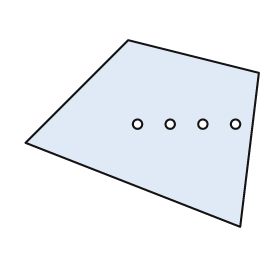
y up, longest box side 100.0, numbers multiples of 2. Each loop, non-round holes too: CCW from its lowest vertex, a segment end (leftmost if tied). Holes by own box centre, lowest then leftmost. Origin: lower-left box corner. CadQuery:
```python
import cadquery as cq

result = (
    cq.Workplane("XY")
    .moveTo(92.0, 0.0)
    .lineTo(100.0, 66.0)
    .lineTo(44.0, 80.0)
    .lineTo(0.0, 36.0)
    .close()
    .moveTo(48.0, 44.0)
    .circle(2.0)
    .moveTo(62.0, 44.0)
    .circle(2.0)
    .moveTo(76.0, 44.0)
    .circle(2.0)
    .moveTo(90.0, 44.0)
    .circle(2.0)
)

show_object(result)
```